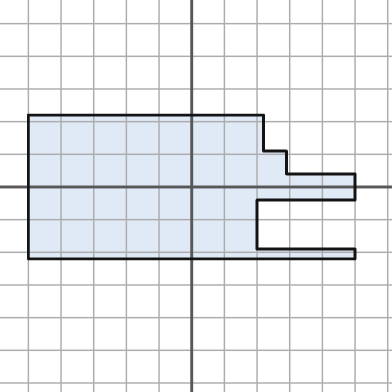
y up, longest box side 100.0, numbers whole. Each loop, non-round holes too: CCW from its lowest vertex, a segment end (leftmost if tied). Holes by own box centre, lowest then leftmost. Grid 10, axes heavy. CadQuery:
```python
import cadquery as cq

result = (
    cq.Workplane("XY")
    .moveTo(-50.0, -22.0)
    .lineTo(50.0, -22.0)
    .lineTo(50.0, -19.0)
    .lineTo(20.0, -19.0)
    .lineTo(20.0, -4.0)
    .lineTo(50.0, -4.0)
    .lineTo(50.0, 4.0)
    .lineTo(29.0, 4.0)
    .lineTo(29.0, 11.0)
    .lineTo(22.0, 11.0)
    .lineTo(22.0, 22.0)
    .lineTo(-50.0, 22.0)
    .close()
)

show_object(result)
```